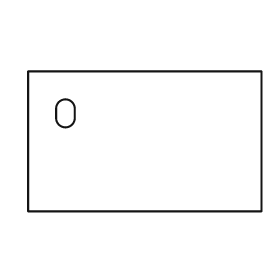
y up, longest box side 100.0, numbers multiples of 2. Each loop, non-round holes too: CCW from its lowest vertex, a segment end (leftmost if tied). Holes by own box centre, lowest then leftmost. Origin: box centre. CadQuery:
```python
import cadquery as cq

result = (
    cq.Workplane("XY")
    .moveTo(-50.0, -30.0)
    .lineTo(50.0, -30.0)
    .lineTo(50.0, 30.0)
    .lineTo(-50.0, 30.0)
    .close()
    .moveTo(-38.0, 10.0)
    .threePointArc((-34.0, 6.0), (-30.0, 10.0))
    .lineTo(-30.0, 14.0)
    .threePointArc((-34.0, 18.0), (-38.0, 14.0))
    .close()
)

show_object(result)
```